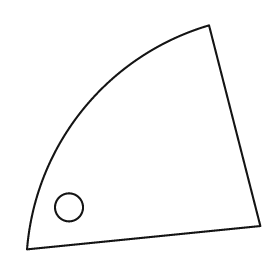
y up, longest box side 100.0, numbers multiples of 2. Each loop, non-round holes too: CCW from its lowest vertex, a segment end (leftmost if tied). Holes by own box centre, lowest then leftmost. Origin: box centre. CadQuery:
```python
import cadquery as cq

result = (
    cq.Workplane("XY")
    .moveTo(-50.0, -48.0)
    .lineTo(50.0, -38.0)
    .lineTo(28.0, 48.0)
    .threePointArc((-26.0, 12.0), (-50.0, -48.0))
    .close()
    .moveTo(-32.0, -30.0)
    .circle(6.0)
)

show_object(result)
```